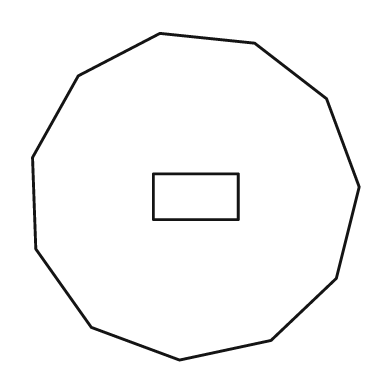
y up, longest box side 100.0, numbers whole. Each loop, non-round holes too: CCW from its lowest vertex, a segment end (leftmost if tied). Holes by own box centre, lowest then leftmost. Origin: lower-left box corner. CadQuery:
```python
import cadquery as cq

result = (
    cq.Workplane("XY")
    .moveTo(45.0, 0.0)
    .lineTo(73.0, 6.0)
    .lineTo(93.0, 25.0)
    .lineTo(100.0, 53.0)
    .lineTo(90.0, 80.0)
    .lineTo(68.0, 97.0)
    .lineTo(39.0, 100.0)
    .lineTo(14.0, 87.0)
    .lineTo(0.0, 62.0)
    .lineTo(1.0, 34.0)
    .lineTo(18.0, 10.0)
    .close()
    .moveTo(37.0, 43.0)
    .lineTo(63.0, 43.0)
    .lineTo(63.0, 57.0)
    .lineTo(37.0, 57.0)
    .close()
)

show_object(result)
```